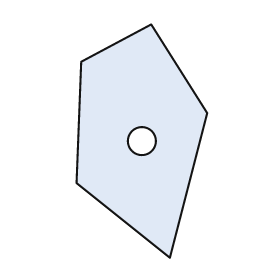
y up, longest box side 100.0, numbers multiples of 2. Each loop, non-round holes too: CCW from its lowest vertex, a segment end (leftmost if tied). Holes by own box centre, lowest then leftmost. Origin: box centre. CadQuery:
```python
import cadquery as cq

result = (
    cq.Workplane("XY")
    .moveTo(12.0, -50.0)
    .lineTo(28.0, 12.0)
    .lineTo(4.0, 50.0)
    .lineTo(-26.0, 34.0)
    .lineTo(-28.0, -18.0)
    .close()
    .moveTo(0.0, 0.0)
    .circle(6.0)
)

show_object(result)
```